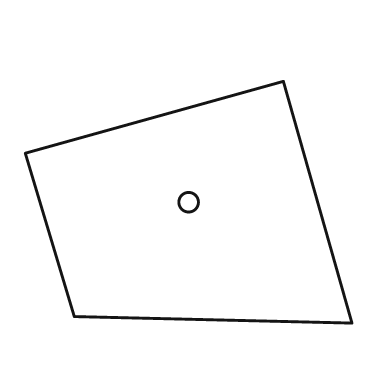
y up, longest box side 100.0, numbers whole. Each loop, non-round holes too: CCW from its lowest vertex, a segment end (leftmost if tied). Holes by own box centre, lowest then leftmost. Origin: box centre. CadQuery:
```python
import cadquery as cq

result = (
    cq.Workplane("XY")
    .moveTo(50.0, -37.0)
    .lineTo(29.0, 37.0)
    .lineTo(-50.0, 15.0)
    .lineTo(-35.0, -35.0)
    .close()
    .moveTo(0.0, 0.0)
    .circle(3.0)
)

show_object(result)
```